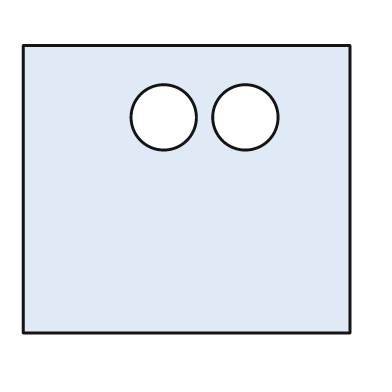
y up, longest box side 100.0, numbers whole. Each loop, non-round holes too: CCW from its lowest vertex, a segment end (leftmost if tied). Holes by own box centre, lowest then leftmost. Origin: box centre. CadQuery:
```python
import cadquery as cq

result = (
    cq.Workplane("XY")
    .moveTo(-50.0, -44.0)
    .lineTo(50.0, -44.0)
    .lineTo(50.0, 44.0)
    .lineTo(-50.0, 44.0)
    .close()
    .moveTo(-7.0, 22.0)
    .circle(10.0)
    .moveTo(18.0, 22.0)
    .circle(10.0)
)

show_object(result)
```